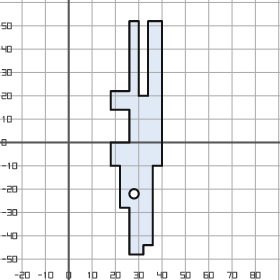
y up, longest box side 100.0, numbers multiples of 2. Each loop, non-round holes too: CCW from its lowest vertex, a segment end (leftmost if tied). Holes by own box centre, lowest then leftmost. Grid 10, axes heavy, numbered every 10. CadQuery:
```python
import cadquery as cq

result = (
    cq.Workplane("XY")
    .moveTo(26.0, -48.0)
    .lineTo(32.0, -48.0)
    .lineTo(32.0, -44.0)
    .lineTo(36.0, -44.0)
    .lineTo(36.0, -10.0)
    .lineTo(40.0, -10.0)
    .lineTo(40.0, 52.0)
    .lineTo(34.0, 52.0)
    .lineTo(34.0, 20.0)
    .lineTo(30.0, 20.0)
    .lineTo(30.0, 52.0)
    .lineTo(26.0, 52.0)
    .lineTo(26.0, 22.0)
    .lineTo(18.0, 22.0)
    .lineTo(18.0, 14.0)
    .lineTo(26.0, 14.0)
    .lineTo(26.0, 0.0)
    .lineTo(18.0, 0.0)
    .lineTo(18.0, -10.0)
    .lineTo(22.0, -10.0)
    .lineTo(22.0, -28.0)
    .lineTo(26.0, -28.0)
    .close()
    .moveTo(28.0, -22.0)
    .circle(2.0)
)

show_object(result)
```